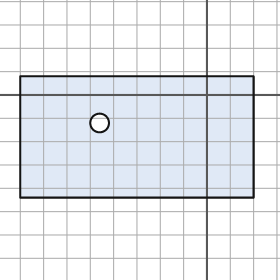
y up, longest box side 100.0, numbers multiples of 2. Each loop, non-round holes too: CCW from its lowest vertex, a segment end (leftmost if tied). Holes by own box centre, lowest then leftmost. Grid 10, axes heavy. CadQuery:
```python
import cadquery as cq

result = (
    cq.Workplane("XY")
    .moveTo(-80.0, -44.0)
    .lineTo(20.0, -44.0)
    .lineTo(20.0, 8.0)
    .lineTo(-80.0, 8.0)
    .close()
    .moveTo(-46.0, -12.0)
    .circle(4.0)
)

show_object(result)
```